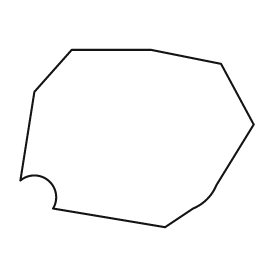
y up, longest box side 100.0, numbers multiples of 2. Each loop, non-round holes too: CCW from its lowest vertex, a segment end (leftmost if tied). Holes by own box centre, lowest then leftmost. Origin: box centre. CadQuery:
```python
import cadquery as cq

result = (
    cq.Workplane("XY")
    .moveTo(12.0, -38.0)
    .lineTo(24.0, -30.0)
    .threePointArc((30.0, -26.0), (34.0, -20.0))
    .lineTo(50.0, 6.0)
    .lineTo(36.0, 32.0)
    .lineTo(6.0, 38.0)
    .lineTo(-28.0, 38.0)
    .lineTo(-44.0, 20.0)
    .lineTo(-50.0, -18.0)
    .threePointArc((-38.0, -18.0), (-36.0, -30.0))
    .close()
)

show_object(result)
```